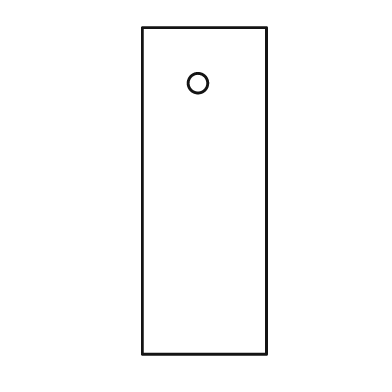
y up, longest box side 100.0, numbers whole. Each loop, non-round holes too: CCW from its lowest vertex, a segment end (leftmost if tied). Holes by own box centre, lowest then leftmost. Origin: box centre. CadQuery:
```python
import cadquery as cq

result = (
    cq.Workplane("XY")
    .moveTo(-19.0, -50.0)
    .lineTo(19.0, -50.0)
    .lineTo(19.0, 50.0)
    .lineTo(-19.0, 50.0)
    .close()
    .moveTo(-2.0, 33.0)
    .circle(3.0)
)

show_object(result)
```